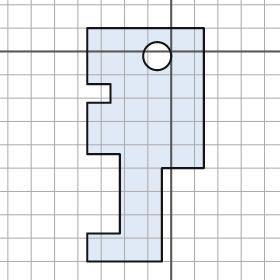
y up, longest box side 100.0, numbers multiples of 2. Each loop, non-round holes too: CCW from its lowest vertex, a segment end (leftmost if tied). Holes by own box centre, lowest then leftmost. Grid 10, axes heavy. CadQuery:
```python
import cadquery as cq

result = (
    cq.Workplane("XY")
    .moveTo(-36.0, -90.0)
    .lineTo(-4.0, -90.0)
    .lineTo(-4.0, -50.0)
    .lineTo(14.0, -50.0)
    .lineTo(14.0, 10.0)
    .lineTo(-36.0, 10.0)
    .lineTo(-36.0, -14.0)
    .lineTo(-26.0, -14.0)
    .lineTo(-26.0, -22.0)
    .lineTo(-36.0, -22.0)
    .lineTo(-36.0, -44.0)
    .lineTo(-22.0, -44.0)
    .lineTo(-22.0, -78.0)
    .lineTo(-36.0, -78.0)
    .close()
    .moveTo(-6.0, -2.0)
    .circle(6.0)
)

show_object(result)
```